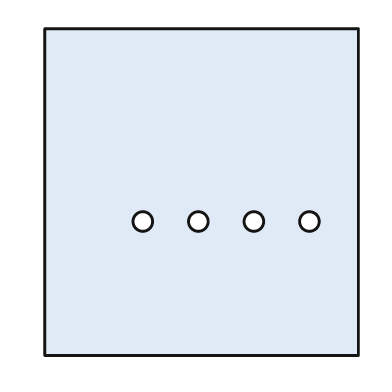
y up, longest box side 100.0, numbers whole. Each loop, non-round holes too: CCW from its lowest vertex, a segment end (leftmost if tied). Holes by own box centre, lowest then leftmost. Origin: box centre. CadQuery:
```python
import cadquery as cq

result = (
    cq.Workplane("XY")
    .moveTo(-48.0, -50.0)
    .lineTo(48.0, -50.0)
    .lineTo(48.0, 50.0)
    .lineTo(-48.0, 50.0)
    .close()
    .moveTo(-18.0, -9.0)
    .circle(3.0)
    .moveTo(-1.0, -9.0)
    .circle(3.0)
    .moveTo(16.0, -9.0)
    .circle(3.0)
    .moveTo(33.0, -9.0)
    .circle(3.0)
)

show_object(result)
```